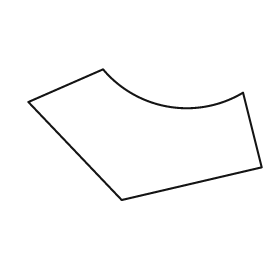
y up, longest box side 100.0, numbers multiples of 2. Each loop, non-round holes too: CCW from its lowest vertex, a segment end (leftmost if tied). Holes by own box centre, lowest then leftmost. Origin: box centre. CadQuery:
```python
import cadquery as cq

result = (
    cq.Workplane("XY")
    .moveTo(-10.0, -28.0)
    .lineTo(50.0, -14.0)
    .lineTo(42.0, 18.0)
    .threePointArc((10.0, 12.0), (-18.0, 28.0))
    .lineTo(-50.0, 14.0)
    .close()
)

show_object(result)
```